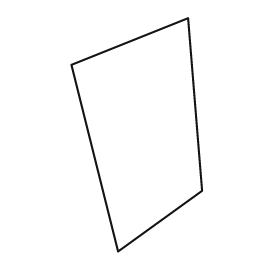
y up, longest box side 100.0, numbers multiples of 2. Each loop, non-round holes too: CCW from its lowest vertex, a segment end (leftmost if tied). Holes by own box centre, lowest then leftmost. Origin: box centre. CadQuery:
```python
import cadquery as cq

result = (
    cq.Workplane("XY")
    .moveTo(-8.0, -50.0)
    .lineTo(28.0, -24.0)
    .lineTo(22.0, 50.0)
    .lineTo(-28.0, 30.0)
    .close()
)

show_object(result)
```